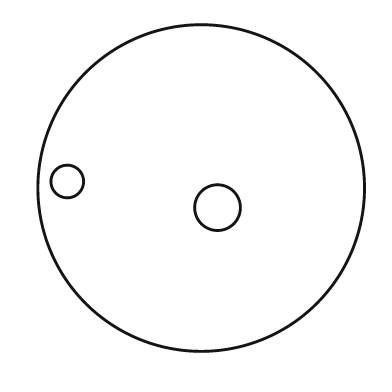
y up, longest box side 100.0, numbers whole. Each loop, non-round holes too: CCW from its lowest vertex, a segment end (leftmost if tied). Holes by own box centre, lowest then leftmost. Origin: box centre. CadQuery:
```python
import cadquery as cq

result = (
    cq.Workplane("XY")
    .moveTo(0.0, 0.0)
    .circle(50.0)
    .moveTo(5.0, -6.0)
    .circle(7.0)
    .moveTo(-41.0, 2.0)
    .circle(5.0)
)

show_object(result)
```